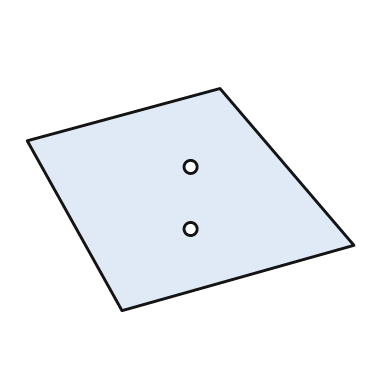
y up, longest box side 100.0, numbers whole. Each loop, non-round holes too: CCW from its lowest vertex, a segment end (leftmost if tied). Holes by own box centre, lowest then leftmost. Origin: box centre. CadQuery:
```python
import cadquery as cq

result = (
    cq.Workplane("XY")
    .moveTo(-21.0, -34.0)
    .lineTo(50.0, -14.0)
    .lineTo(9.0, 34.0)
    .lineTo(-50.0, 18.0)
    .close()
    .moveTo(0.0, -9.0)
    .circle(2.0)
    .moveTo(0.0, 10.0)
    .circle(2.0)
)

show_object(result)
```